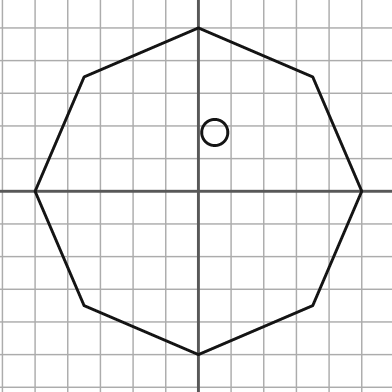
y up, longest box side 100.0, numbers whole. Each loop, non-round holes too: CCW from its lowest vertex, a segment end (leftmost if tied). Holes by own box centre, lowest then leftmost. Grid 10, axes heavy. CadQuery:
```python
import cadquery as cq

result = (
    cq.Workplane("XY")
    .moveTo(0.0, -50.0)
    .lineTo(35.0, -35.0)
    .lineTo(50.0, 0.0)
    .lineTo(35.0, 35.0)
    .lineTo(0.0, 50.0)
    .lineTo(-35.0, 35.0)
    .lineTo(-50.0, 0.0)
    .lineTo(-35.0, -35.0)
    .close()
    .moveTo(5.0, 18.0)
    .circle(4.0)
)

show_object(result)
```